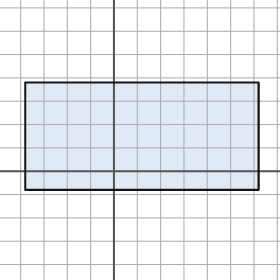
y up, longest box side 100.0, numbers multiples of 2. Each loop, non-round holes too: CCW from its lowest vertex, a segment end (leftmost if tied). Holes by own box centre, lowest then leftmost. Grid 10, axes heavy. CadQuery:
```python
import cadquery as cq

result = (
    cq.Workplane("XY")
    .moveTo(-38.0, -8.0)
    .lineTo(62.0, -8.0)
    .lineTo(62.0, 38.0)
    .lineTo(-38.0, 38.0)
    .close()
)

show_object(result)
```